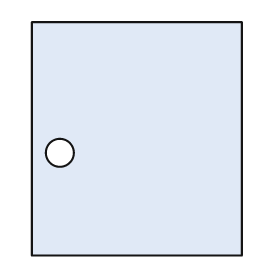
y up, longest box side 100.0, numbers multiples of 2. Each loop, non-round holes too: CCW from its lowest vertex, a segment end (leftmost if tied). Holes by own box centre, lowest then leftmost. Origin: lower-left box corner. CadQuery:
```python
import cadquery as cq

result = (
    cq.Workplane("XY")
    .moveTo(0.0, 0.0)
    .lineTo(90.0, 0.0)
    .lineTo(90.0, 100.0)
    .lineTo(0.0, 100.0)
    .close()
    .moveTo(12.0, 44.0)
    .circle(6.0)
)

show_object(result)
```